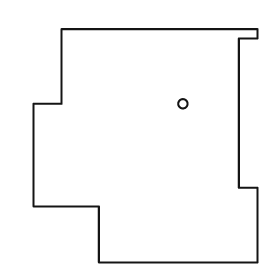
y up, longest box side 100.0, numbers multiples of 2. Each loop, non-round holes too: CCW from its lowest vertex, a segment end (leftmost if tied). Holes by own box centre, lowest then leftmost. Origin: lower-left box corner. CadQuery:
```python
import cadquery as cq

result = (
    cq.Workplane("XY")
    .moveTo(28.0, 0.0)
    .lineTo(96.0, 0.0)
    .lineTo(96.0, 32.0)
    .lineTo(88.0, 32.0)
    .lineTo(88.0, 96.0)
    .lineTo(96.0, 96.0)
    .lineTo(96.0, 100.0)
    .lineTo(12.0, 100.0)
    .lineTo(12.0, 68.0)
    .lineTo(0.0, 68.0)
    .lineTo(0.0, 24.0)
    .lineTo(28.0, 24.0)
    .close()
    .moveTo(64.0, 68.0)
    .circle(2.0)
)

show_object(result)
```